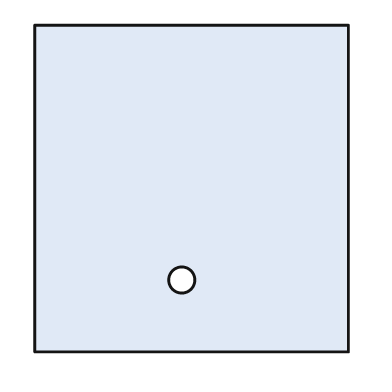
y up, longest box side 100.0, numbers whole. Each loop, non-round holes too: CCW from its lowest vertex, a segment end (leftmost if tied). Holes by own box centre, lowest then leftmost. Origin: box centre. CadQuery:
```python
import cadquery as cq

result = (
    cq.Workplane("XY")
    .moveTo(-48.0, -50.0)
    .lineTo(48.0, -50.0)
    .lineTo(48.0, 50.0)
    .lineTo(-48.0, 50.0)
    .close()
    .moveTo(-3.0, -28.0)
    .circle(4.0)
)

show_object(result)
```